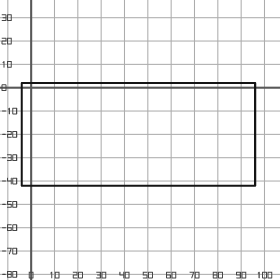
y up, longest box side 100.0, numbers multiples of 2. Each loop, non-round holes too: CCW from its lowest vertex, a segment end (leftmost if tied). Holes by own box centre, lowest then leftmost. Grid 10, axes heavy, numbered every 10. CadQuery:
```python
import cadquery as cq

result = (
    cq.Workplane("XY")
    .moveTo(-4.0, -42.0)
    .lineTo(96.0, -42.0)
    .lineTo(96.0, 2.0)
    .lineTo(-4.0, 2.0)
    .close()
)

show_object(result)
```